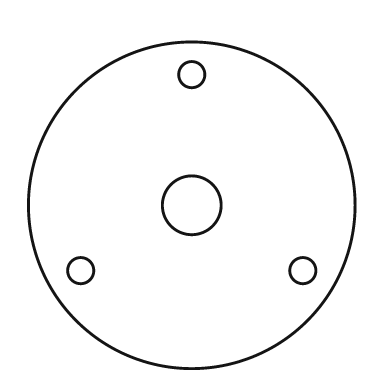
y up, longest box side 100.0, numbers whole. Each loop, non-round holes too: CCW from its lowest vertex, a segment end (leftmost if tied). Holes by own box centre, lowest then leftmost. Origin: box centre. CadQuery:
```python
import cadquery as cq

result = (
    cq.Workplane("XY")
    .moveTo(0.0, 0.0)
    .circle(50.0)
    .moveTo(-34.0, -20.0)
    .circle(4.0)
    .moveTo(34.0, -20.0)
    .circle(4.0)
    .moveTo(0.0, 0.0)
    .circle(9.0)
    .moveTo(0.0, 40.0)
    .circle(4.0)
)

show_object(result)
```